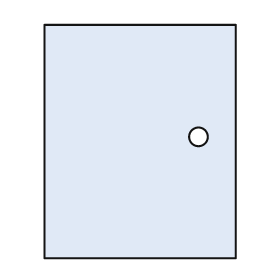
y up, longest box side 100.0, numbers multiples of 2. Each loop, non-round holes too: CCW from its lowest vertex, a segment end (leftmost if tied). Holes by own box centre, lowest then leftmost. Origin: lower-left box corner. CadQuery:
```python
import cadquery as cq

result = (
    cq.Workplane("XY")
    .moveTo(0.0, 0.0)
    .lineTo(82.0, 0.0)
    .lineTo(82.0, 100.0)
    .lineTo(0.0, 100.0)
    .close()
    .moveTo(66.0, 52.0)
    .circle(4.0)
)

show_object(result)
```